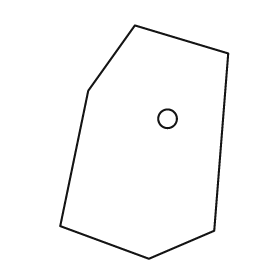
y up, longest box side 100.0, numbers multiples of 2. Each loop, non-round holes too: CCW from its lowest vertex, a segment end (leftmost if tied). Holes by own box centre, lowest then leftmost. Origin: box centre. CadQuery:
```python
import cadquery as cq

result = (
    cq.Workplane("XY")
    .moveTo(2.0, -50.0)
    .lineTo(30.0, -38.0)
    .lineTo(36.0, 38.0)
    .lineTo(-4.0, 50.0)
    .lineTo(-24.0, 22.0)
    .lineTo(-36.0, -36.0)
    .close()
    .moveTo(10.0, 10.0)
    .circle(4.0)
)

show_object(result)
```